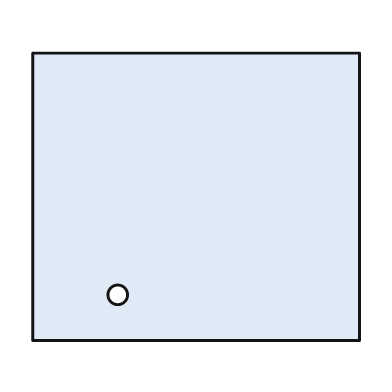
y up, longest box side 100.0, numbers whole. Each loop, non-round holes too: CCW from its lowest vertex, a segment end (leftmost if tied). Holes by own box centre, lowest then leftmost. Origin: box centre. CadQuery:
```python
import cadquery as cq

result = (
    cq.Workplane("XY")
    .moveTo(-50.0, -44.0)
    .lineTo(50.0, -44.0)
    .lineTo(50.0, 44.0)
    .lineTo(-50.0, 44.0)
    .close()
    .moveTo(-24.0, -30.0)
    .circle(3.0)
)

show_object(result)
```